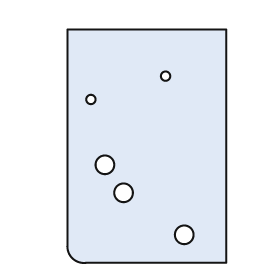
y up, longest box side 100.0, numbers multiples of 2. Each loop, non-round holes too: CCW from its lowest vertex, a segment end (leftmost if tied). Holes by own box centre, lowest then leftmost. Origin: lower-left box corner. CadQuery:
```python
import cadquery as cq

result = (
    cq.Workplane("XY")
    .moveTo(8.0, 0.0)
    .lineTo(68.0, 0.0)
    .lineTo(68.0, 100.0)
    .lineTo(0.0, 100.0)
    .lineTo(0.0, 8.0)
    .threePointArc((2.0, 2.0), (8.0, 0.0))
    .close()
    .moveTo(50.0, 12.0)
    .circle(4.0)
    .moveTo(24.0, 30.0)
    .circle(4.0)
    .moveTo(16.0, 42.0)
    .circle(4.0)
    .moveTo(10.0, 70.0)
    .circle(2.0)
    .moveTo(42.0, 80.0)
    .circle(2.0)
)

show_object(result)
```